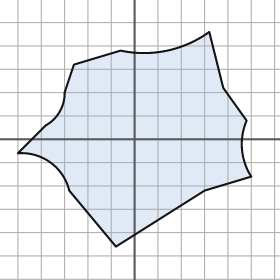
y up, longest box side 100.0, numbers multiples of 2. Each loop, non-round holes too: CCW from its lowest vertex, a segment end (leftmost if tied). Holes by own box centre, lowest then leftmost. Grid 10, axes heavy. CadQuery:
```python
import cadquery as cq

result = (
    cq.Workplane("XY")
    .moveTo(-8.0, -46.0)
    .lineTo(30.0, -22.0)
    .lineTo(50.0, -16.0)
    .threePointArc((46.0, -4.0), (48.0, 8.0))
    .lineTo(38.0, 22.0)
    .lineTo(32.0, 46.0)
    .threePointArc((14.0, 38.0), (-6.0, 38.0))
    .lineTo(-26.0, 32.0)
    .lineTo(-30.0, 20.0)
    .threePointArc((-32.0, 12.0), (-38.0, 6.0))
    .lineTo(-50.0, -6.0)
    .threePointArc((-36.0, -10.0), (-28.0, -22.0))
    .close()
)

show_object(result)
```